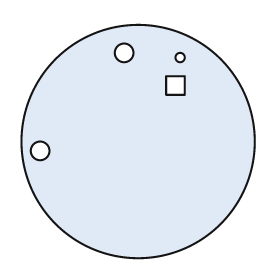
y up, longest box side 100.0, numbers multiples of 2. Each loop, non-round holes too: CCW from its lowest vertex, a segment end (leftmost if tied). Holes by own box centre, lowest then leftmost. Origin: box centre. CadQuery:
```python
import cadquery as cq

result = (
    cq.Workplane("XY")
    .moveTo(0.0, 0.0)
    .circle(50.0)
    .moveTo(-42.0, -4.0)
    .circle(4.0)
    .moveTo(12.0, 20.0)
    .lineTo(20.0, 20.0)
    .lineTo(20.0, 28.0)
    .lineTo(12.0, 28.0)
    .close()
    .moveTo(18.0, 36.0)
    .circle(2.0)
    .moveTo(-6.0, 38.0)
    .circle(4.0)
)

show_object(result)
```